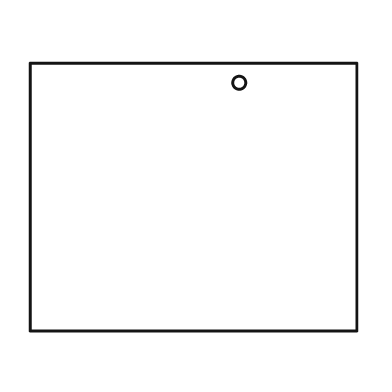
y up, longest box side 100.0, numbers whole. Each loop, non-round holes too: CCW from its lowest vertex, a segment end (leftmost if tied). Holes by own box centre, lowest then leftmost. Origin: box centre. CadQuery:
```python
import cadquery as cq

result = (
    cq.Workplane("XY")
    .moveTo(-50.0, -41.0)
    .lineTo(50.0, -41.0)
    .lineTo(50.0, 41.0)
    .lineTo(-50.0, 41.0)
    .close()
    .moveTo(14.0, 35.0)
    .circle(2.0)
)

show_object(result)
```